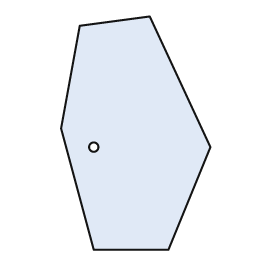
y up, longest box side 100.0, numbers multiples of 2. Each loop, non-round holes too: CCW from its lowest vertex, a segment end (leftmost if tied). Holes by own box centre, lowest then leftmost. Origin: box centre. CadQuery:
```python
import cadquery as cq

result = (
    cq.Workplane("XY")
    .moveTo(-18.0, -50.0)
    .lineTo(14.0, -50.0)
    .lineTo(32.0, -6.0)
    .lineTo(6.0, 50.0)
    .lineTo(-24.0, 46.0)
    .lineTo(-32.0, 2.0)
    .close()
    .moveTo(-18.0, -6.0)
    .circle(2.0)
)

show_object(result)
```